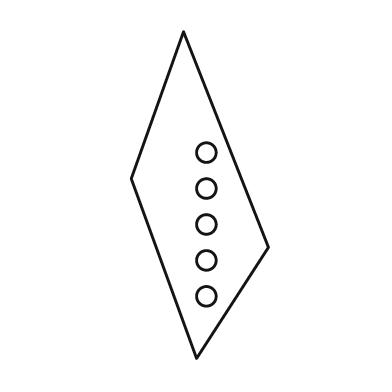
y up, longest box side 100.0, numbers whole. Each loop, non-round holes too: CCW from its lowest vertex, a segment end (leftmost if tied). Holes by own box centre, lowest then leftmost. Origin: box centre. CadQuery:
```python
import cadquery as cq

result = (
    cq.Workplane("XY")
    .moveTo(-1.0, -50.0)
    .lineTo(21.0, -16.0)
    .lineTo(-5.0, 50.0)
    .lineTo(-21.0, 5.0)
    .close()
    .moveTo(2.0, -31.0)
    .circle(3.0)
    .moveTo(2.0, -20.0)
    .circle(3.0)
    .moveTo(2.0, -9.0)
    .circle(3.0)
    .moveTo(2.0, 2.0)
    .circle(3.0)
    .moveTo(2.0, 13.0)
    .circle(3.0)
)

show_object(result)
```